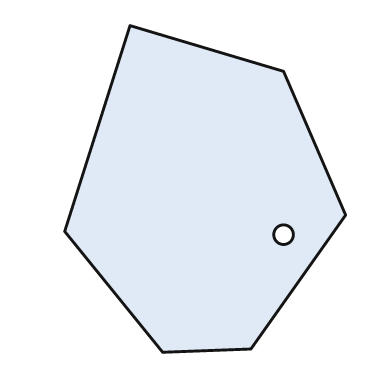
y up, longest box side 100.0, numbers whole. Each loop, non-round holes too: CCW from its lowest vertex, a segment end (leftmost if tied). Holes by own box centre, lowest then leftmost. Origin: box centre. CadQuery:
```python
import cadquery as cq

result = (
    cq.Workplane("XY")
    .moveTo(-13.0, -50.0)
    .lineTo(14.0, -49.0)
    .lineTo(43.0, -8.0)
    .lineTo(24.0, 36.0)
    .lineTo(-23.0, 50.0)
    .lineTo(-43.0, -13.0)
    .close()
    .moveTo(24.0, -14.0)
    .circle(3.0)
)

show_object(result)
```